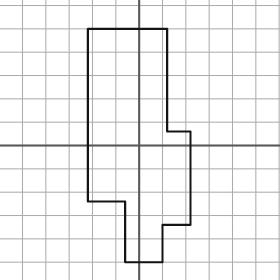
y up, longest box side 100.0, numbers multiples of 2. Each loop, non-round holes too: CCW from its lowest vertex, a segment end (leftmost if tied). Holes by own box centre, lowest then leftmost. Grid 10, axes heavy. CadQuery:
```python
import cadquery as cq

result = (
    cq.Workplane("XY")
    .moveTo(-6.0, -50.0)
    .lineTo(10.0, -50.0)
    .lineTo(10.0, -34.0)
    .lineTo(22.0, -34.0)
    .lineTo(22.0, 6.0)
    .lineTo(12.0, 6.0)
    .lineTo(12.0, 50.0)
    .lineTo(-22.0, 50.0)
    .lineTo(-22.0, -24.0)
    .lineTo(-6.0, -24.0)
    .close()
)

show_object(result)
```